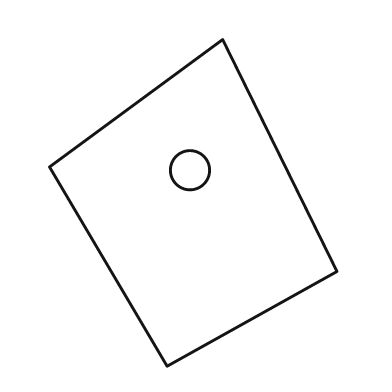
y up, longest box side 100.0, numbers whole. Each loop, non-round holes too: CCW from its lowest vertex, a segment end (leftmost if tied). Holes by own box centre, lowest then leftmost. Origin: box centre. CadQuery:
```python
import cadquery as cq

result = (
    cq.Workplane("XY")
    .moveTo(-8.0, -50.0)
    .lineTo(44.0, -21.0)
    .lineTo(9.0, 50.0)
    .lineTo(-44.0, 11.0)
    .close()
    .moveTo(-1.0, 10.0)
    .circle(6.0)
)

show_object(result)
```